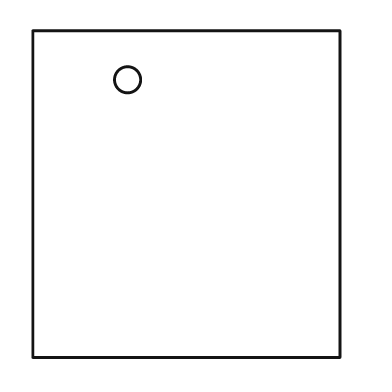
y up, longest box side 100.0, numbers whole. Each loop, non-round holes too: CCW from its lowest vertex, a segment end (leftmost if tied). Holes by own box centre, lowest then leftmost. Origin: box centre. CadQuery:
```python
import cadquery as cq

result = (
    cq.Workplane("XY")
    .moveTo(-47.0, -50.0)
    .lineTo(47.0, -50.0)
    .lineTo(47.0, 50.0)
    .lineTo(-47.0, 50.0)
    .close()
    .moveTo(-18.0, 35.0)
    .circle(4.0)
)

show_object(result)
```